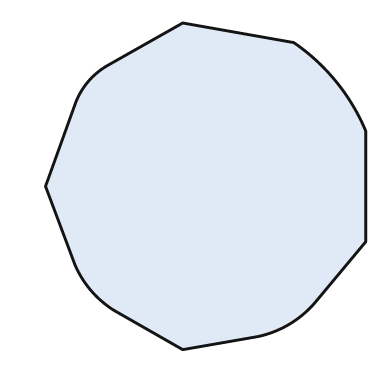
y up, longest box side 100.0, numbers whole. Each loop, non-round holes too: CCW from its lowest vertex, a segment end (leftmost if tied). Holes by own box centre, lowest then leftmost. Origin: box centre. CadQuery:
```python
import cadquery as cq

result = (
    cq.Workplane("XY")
    .moveTo(-7.0, -50.0)
    .lineTo(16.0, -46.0)
    .threePointArc((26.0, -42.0), (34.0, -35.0))
    .lineTo(49.0, -17.0)
    .lineTo(49.0, 17.0)
    .threePointArc((40.0, 32.0), (27.0, 44.0))
    .lineTo(-7.0, 50.0)
    .lineTo(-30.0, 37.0)
    .threePointArc((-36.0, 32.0), (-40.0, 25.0))
    .lineTo(-49.0, 0.0)
    .lineTo(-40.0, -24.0)
    .threePointArc((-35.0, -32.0), (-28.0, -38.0))
    .close()
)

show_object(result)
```